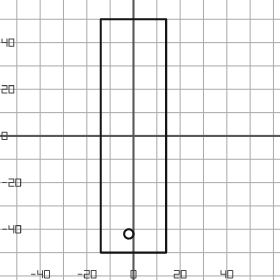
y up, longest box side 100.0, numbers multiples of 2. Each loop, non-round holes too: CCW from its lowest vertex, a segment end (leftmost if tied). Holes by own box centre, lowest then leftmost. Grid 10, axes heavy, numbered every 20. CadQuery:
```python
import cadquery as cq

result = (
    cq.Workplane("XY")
    .moveTo(-14.0, -50.0)
    .lineTo(14.0, -50.0)
    .lineTo(14.0, 50.0)
    .lineTo(-14.0, 50.0)
    .close()
    .moveTo(-2.0, -42.0)
    .circle(2.0)
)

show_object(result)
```